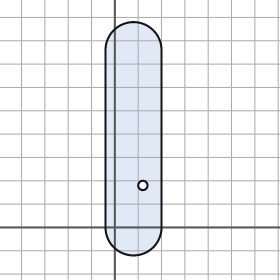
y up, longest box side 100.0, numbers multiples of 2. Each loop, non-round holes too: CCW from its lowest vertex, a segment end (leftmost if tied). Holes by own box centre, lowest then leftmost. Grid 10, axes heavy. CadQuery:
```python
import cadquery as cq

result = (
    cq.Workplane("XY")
    .moveTo(-4.0, 0.0)
    .threePointArc((8.0, -12.0), (20.0, 0.0))
    .lineTo(20.0, 76.0)
    .threePointArc((8.0, 88.0), (-4.0, 76.0))
    .close()
    .moveTo(12.0, 18.0)
    .circle(2.0)
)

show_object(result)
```